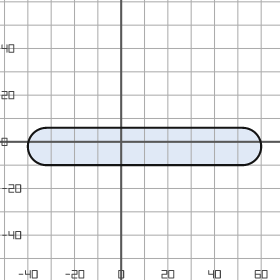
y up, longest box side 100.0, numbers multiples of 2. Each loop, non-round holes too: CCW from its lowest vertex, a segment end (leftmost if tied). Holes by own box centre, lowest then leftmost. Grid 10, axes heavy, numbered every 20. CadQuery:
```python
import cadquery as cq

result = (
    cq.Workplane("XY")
    .moveTo(-32.0, -10.0)
    .lineTo(52.0, -10.0)
    .threePointArc((60.0, -2.0), (52.0, 6.0))
    .lineTo(-32.0, 6.0)
    .threePointArc((-40.0, -2.0), (-32.0, -10.0))
    .close()
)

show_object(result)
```